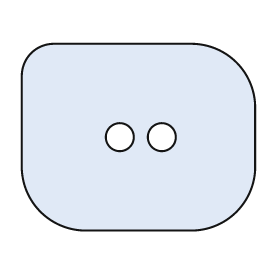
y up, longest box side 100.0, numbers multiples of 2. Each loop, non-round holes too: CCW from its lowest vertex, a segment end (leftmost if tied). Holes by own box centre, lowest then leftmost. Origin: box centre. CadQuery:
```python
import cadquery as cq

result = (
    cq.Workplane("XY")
    .moveTo(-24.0, -40.0)
    .lineTo(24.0, -40.0)
    .threePointArc((42.0, -32.0), (50.0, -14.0))
    .lineTo(50.0, 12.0)
    .threePointArc((42.0, 32.0), (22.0, 40.0))
    .lineTo(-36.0, 40.0)
    .threePointArc((-46.0, 36.0), (-50.0, 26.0))
    .lineTo(-50.0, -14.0)
    .threePointArc((-42.0, -32.0), (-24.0, -40.0))
    .close()
    .moveTo(-8.0, 0.0)
    .circle(6.0)
    .moveTo(10.0, 0.0)
    .circle(6.0)
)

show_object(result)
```